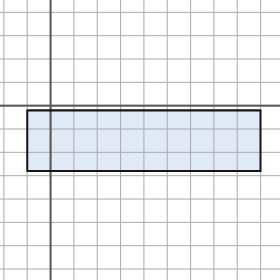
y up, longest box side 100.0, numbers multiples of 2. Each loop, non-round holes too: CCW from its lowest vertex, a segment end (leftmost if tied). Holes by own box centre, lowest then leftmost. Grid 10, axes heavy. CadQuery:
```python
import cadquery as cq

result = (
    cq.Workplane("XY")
    .moveTo(-10.0, -28.0)
    .lineTo(90.0, -28.0)
    .lineTo(90.0, -2.0)
    .lineTo(-10.0, -2.0)
    .close()
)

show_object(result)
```